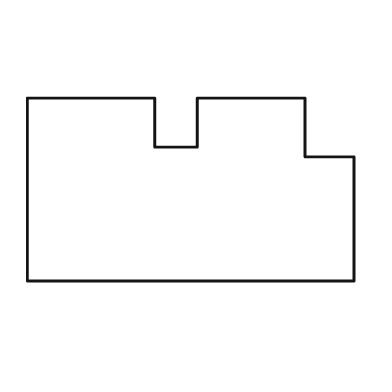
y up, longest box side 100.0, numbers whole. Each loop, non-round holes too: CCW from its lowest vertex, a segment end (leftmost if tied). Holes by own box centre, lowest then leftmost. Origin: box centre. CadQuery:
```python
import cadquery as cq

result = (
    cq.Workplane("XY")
    .moveTo(-50.0, -28.0)
    .lineTo(50.0, -28.0)
    .lineTo(50.0, 10.0)
    .lineTo(35.0, 10.0)
    .lineTo(35.0, 28.0)
    .lineTo(2.0, 28.0)
    .lineTo(2.0, 13.0)
    .lineTo(-11.0, 13.0)
    .lineTo(-11.0, 28.0)
    .lineTo(-50.0, 28.0)
    .close()
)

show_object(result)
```